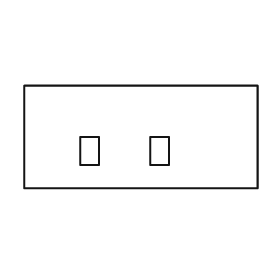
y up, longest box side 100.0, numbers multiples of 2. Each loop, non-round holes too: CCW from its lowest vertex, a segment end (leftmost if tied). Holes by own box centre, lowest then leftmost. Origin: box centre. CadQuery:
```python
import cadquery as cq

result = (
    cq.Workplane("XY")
    .moveTo(-50.0, -22.0)
    .lineTo(50.0, -22.0)
    .lineTo(50.0, 22.0)
    .lineTo(-50.0, 22.0)
    .close()
    .moveTo(-26.0, -12.0)
    .lineTo(-18.0, -12.0)
    .lineTo(-18.0, 0.0)
    .lineTo(-26.0, 0.0)
    .close()
    .moveTo(4.0, -12.0)
    .lineTo(12.0, -12.0)
    .lineTo(12.0, 0.0)
    .lineTo(4.0, 0.0)
    .close()
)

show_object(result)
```